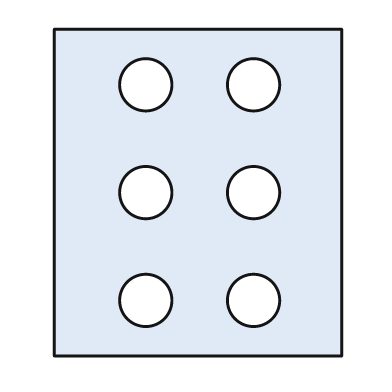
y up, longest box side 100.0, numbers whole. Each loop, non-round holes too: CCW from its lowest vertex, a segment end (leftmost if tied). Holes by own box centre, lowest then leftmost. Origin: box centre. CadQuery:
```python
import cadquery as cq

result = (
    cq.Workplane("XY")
    .moveTo(-44.0, -50.0)
    .lineTo(44.0, -50.0)
    .lineTo(44.0, 50.0)
    .lineTo(-44.0, 50.0)
    .close()
    .moveTo(-16.0, -33.0)
    .circle(8.0)
    .moveTo(17.0, -33.0)
    .circle(8.0)
    .moveTo(-16.0, 0.0)
    .circle(8.0)
    .moveTo(17.0, 0.0)
    .circle(8.0)
    .moveTo(-16.0, 33.0)
    .circle(8.0)
    .moveTo(17.0, 33.0)
    .circle(8.0)
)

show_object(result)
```